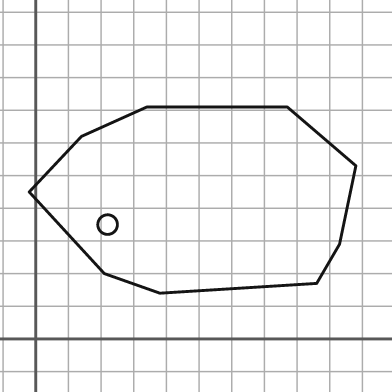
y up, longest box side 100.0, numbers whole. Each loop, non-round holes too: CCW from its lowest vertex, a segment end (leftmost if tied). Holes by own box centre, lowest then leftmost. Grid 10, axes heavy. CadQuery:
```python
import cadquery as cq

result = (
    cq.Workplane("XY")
    .moveTo(38.0, 14.0)
    .lineTo(86.0, 17.0)
    .lineTo(93.0, 29.0)
    .lineTo(98.0, 53.0)
    .lineTo(77.0, 71.0)
    .lineTo(34.0, 71.0)
    .lineTo(14.0, 62.0)
    .lineTo(-2.0, 45.0)
    .lineTo(21.0, 20.0)
    .close()
    .moveTo(22.0, 35.0)
    .circle(3.0)
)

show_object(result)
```